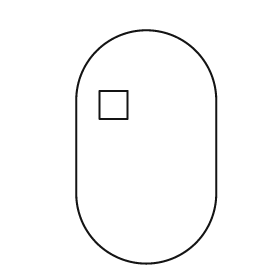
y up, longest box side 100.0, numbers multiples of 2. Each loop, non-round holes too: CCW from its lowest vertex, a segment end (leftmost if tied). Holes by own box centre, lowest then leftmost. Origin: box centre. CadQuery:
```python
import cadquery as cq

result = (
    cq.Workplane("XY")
    .moveTo(-30.0, -20.0)
    .threePointArc((0.0, -50.0), (30.0, -20.0))
    .lineTo(30.0, 20.0)
    .threePointArc((0.0, 50.0), (-30.0, 20.0))
    .close()
    .moveTo(-20.0, 12.0)
    .lineTo(-8.0, 12.0)
    .lineTo(-8.0, 24.0)
    .lineTo(-20.0, 24.0)
    .close()
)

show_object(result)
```